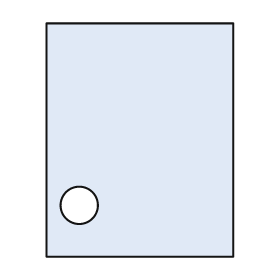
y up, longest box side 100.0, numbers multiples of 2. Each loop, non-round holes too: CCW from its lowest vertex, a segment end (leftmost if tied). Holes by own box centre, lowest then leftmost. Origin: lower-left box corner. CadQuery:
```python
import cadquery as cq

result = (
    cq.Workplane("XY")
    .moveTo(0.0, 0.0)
    .lineTo(80.0, 0.0)
    .lineTo(80.0, 100.0)
    .lineTo(0.0, 100.0)
    .close()
    .moveTo(14.0, 22.0)
    .circle(8.0)
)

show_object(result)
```